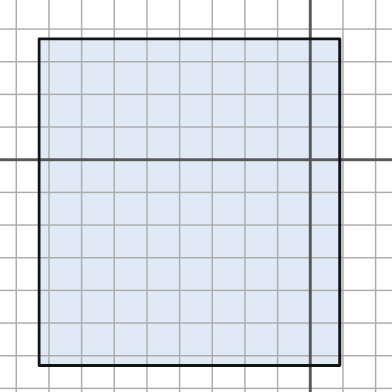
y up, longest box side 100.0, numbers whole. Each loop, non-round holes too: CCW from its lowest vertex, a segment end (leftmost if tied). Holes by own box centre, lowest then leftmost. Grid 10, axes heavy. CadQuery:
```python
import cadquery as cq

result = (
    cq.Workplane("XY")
    .moveTo(-83.0, -63.0)
    .lineTo(9.0, -63.0)
    .lineTo(9.0, 37.0)
    .lineTo(-83.0, 37.0)
    .close()
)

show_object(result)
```